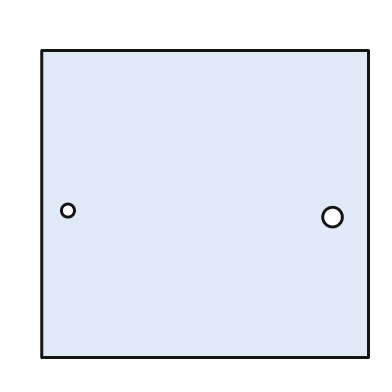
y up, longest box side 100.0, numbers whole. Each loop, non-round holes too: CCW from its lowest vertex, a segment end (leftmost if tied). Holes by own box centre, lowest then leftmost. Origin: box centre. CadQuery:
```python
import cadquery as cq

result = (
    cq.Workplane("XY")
    .moveTo(-50.0, -47.0)
    .lineTo(50.0, -47.0)
    .lineTo(50.0, 47.0)
    .lineTo(-50.0, 47.0)
    .close()
    .moveTo(39.0, -4.0)
    .circle(3.0)
    .moveTo(-42.0, -2.0)
    .circle(2.0)
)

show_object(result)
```